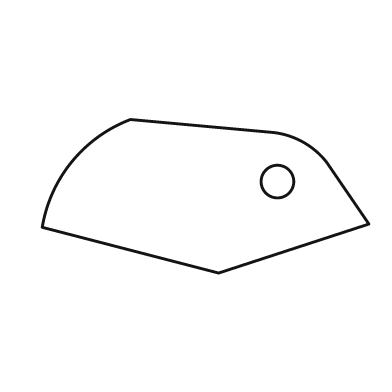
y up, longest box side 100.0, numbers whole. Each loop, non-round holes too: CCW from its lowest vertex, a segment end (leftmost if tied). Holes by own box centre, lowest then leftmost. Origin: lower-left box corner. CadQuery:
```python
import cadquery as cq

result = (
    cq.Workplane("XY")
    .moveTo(54.0, 0.0)
    .lineTo(100.0, 15.0)
    .lineTo(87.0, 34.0)
    .threePointArc((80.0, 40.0), (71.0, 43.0))
    .lineTo(27.0, 47.0)
    .threePointArc((9.0, 34.0), (0.0, 14.0))
    .close()
    .moveTo(72.0, 28.0)
    .circle(5.0)
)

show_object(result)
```